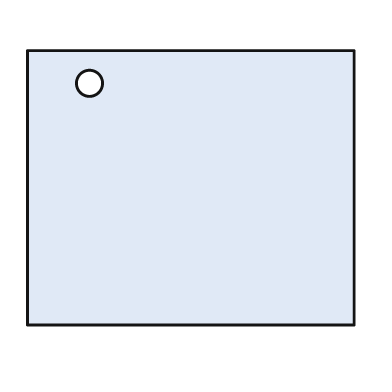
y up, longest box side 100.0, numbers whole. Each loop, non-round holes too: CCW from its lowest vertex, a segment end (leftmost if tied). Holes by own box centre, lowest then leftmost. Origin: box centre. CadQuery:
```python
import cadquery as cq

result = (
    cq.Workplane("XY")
    .moveTo(-50.0, -42.0)
    .lineTo(50.0, -42.0)
    .lineTo(50.0, 42.0)
    .lineTo(-50.0, 42.0)
    .close()
    .moveTo(-31.0, 32.0)
    .circle(4.0)
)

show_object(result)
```